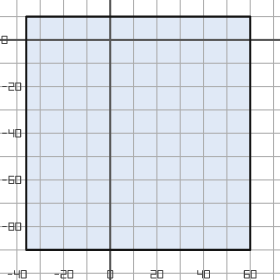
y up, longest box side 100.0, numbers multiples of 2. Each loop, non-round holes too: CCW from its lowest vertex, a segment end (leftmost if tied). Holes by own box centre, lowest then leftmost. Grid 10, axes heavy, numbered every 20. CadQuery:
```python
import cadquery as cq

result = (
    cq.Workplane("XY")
    .moveTo(-36.0, -90.0)
    .lineTo(60.0, -90.0)
    .lineTo(60.0, 10.0)
    .lineTo(-36.0, 10.0)
    .close()
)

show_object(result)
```